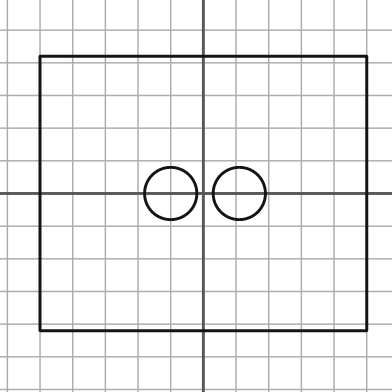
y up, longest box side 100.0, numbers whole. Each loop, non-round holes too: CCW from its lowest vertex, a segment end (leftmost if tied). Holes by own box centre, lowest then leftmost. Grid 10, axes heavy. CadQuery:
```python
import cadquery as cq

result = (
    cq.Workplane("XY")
    .moveTo(-50.0, -42.0)
    .lineTo(50.0, -42.0)
    .lineTo(50.0, 42.0)
    .lineTo(-50.0, 42.0)
    .close()
    .moveTo(-10.0, 0.0)
    .circle(8.0)
    .moveTo(11.0, 0.0)
    .circle(8.0)
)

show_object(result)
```